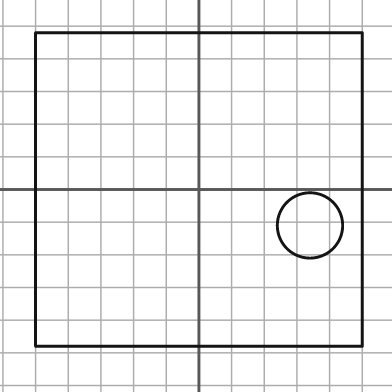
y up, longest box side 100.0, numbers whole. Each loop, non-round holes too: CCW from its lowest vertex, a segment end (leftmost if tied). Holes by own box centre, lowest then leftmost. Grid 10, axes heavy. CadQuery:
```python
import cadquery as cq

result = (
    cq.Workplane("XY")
    .moveTo(-50.0, -48.0)
    .lineTo(50.0, -48.0)
    .lineTo(50.0, 48.0)
    .lineTo(-50.0, 48.0)
    .close()
    .moveTo(34.0, -11.0)
    .circle(10.0)
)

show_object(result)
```